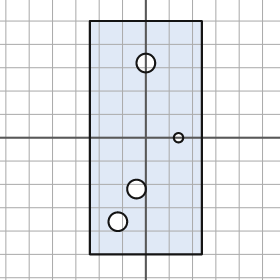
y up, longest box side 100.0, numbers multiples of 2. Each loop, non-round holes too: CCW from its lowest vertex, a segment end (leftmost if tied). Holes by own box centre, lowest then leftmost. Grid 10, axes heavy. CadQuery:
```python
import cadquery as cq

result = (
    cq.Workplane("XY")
    .moveTo(-24.0, -50.0)
    .lineTo(24.0, -50.0)
    .lineTo(24.0, 50.0)
    .lineTo(-24.0, 50.0)
    .close()
    .moveTo(-12.0, -36.0)
    .circle(4.0)
    .moveTo(-4.0, -22.0)
    .circle(4.0)
    .moveTo(14.0, 0.0)
    .circle(2.0)
    .moveTo(0.0, 32.0)
    .circle(4.0)
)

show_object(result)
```